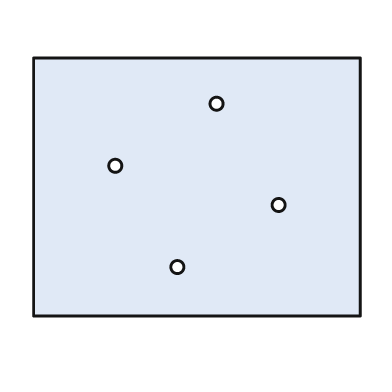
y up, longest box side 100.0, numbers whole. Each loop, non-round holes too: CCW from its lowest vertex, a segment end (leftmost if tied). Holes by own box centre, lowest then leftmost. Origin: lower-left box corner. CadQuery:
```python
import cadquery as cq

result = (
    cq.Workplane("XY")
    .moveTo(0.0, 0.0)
    .lineTo(100.0, 0.0)
    .lineTo(100.0, 79.0)
    .lineTo(0.0, 79.0)
    .close()
    .moveTo(44.0, 15.0)
    .circle(2.0)
    .moveTo(75.0, 34.0)
    .circle(2.0)
    .moveTo(25.0, 46.0)
    .circle(2.0)
    .moveTo(56.0, 65.0)
    .circle(2.0)
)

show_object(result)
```